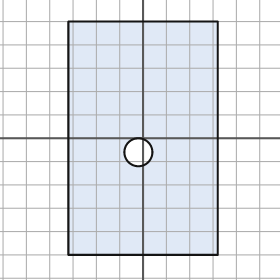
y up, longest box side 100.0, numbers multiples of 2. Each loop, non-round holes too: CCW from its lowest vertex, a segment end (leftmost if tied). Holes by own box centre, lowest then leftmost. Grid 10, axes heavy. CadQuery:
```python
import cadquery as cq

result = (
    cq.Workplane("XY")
    .moveTo(-32.0, -50.0)
    .lineTo(32.0, -50.0)
    .lineTo(32.0, 50.0)
    .lineTo(-32.0, 50.0)
    .close()
    .moveTo(-2.0, -6.0)
    .circle(6.0)
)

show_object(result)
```